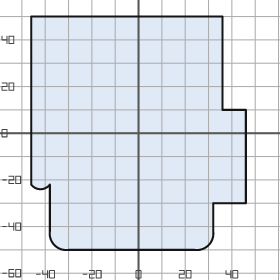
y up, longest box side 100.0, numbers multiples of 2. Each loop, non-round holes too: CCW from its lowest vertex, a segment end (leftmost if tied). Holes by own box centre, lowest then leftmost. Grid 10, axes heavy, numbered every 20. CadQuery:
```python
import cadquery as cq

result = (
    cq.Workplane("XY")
    .moveTo(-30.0, -50.0)
    .lineTo(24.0, -50.0)
    .threePointArc((30.0, -48.0), (32.0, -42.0))
    .lineTo(32.0, -30.0)
    .lineTo(46.0, -30.0)
    .lineTo(46.0, 10.0)
    .lineTo(36.0, 10.0)
    .lineTo(36.0, 50.0)
    .lineTo(-46.0, 50.0)
    .lineTo(-46.0, -22.0)
    .threePointArc((-42.0, -24.0), (-38.0, -22.0))
    .lineTo(-38.0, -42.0)
    .threePointArc((-36.0, -48.0), (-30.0, -50.0))
    .close()
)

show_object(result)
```